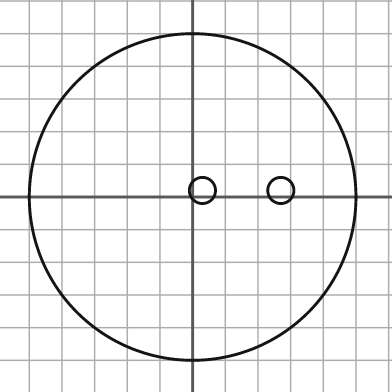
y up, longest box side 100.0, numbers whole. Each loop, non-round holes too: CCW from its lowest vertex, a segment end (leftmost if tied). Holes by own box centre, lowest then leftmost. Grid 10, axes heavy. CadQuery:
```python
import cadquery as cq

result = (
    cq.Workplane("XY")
    .moveTo(0.0, 0.0)
    .circle(50.0)
    .moveTo(3.0, 2.0)
    .circle(4.0)
    .moveTo(27.0, 2.0)
    .circle(4.0)
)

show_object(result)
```